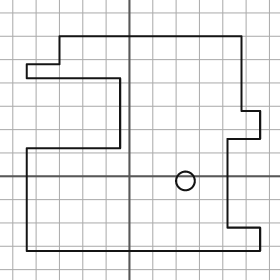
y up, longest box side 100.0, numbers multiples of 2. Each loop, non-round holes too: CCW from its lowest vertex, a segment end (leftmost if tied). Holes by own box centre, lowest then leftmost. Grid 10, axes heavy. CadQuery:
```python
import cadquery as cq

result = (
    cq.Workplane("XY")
    .moveTo(-44.0, -32.0)
    .lineTo(56.0, -32.0)
    .lineTo(56.0, -22.0)
    .lineTo(42.0, -22.0)
    .lineTo(42.0, 16.0)
    .lineTo(56.0, 16.0)
    .lineTo(56.0, 28.0)
    .lineTo(48.0, 28.0)
    .lineTo(48.0, 60.0)
    .lineTo(-30.0, 60.0)
    .lineTo(-30.0, 48.0)
    .lineTo(-44.0, 48.0)
    .lineTo(-44.0, 42.0)
    .lineTo(-4.0, 42.0)
    .lineTo(-4.0, 12.0)
    .lineTo(-44.0, 12.0)
    .close()
    .moveTo(24.0, -2.0)
    .circle(4.0)
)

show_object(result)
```